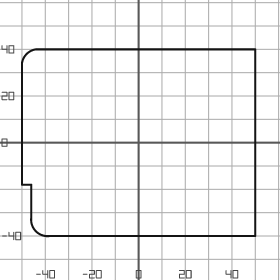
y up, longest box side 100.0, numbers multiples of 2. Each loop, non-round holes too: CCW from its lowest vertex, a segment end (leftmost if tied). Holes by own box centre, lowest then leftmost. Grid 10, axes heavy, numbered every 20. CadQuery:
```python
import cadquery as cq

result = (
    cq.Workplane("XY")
    .moveTo(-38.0, -40.0)
    .lineTo(50.0, -40.0)
    .lineTo(50.0, 40.0)
    .lineTo(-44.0, 40.0)
    .threePointArc((-48.0, 38.0), (-50.0, 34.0))
    .lineTo(-50.0, -18.0)
    .lineTo(-46.0, -18.0)
    .lineTo(-46.0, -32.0)
    .threePointArc((-44.0, -38.0), (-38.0, -40.0))
    .close()
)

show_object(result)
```